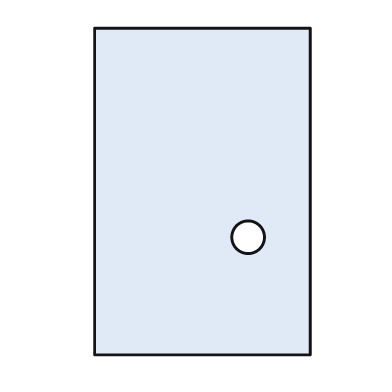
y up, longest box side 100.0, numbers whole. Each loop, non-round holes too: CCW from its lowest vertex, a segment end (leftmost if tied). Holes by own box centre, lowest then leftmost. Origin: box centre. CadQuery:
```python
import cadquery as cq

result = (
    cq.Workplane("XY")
    .moveTo(-33.0, -50.0)
    .lineTo(33.0, -50.0)
    .lineTo(33.0, 50.0)
    .lineTo(-33.0, 50.0)
    .close()
    .moveTo(14.0, -14.0)
    .circle(5.0)
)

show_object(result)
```